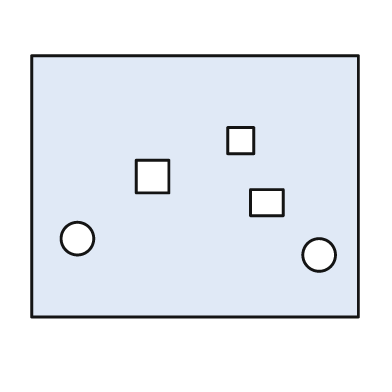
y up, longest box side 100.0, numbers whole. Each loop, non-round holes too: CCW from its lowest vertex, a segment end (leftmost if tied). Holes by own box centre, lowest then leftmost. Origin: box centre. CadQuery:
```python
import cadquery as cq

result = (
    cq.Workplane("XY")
    .moveTo(-50.0, -40.0)
    .lineTo(50.0, -40.0)
    .lineTo(50.0, 40.0)
    .lineTo(-50.0, 40.0)
    .close()
    .moveTo(38.0, -21.0)
    .circle(5.0)
    .moveTo(-36.0, -16.0)
    .circle(5.0)
    .moveTo(17.0, -9.0)
    .lineTo(27.0, -9.0)
    .lineTo(27.0, -1.0)
    .lineTo(17.0, -1.0)
    .close()
    .moveTo(-18.0, -2.0)
    .lineTo(-8.0, -2.0)
    .lineTo(-8.0, 8.0)
    .lineTo(-18.0, 8.0)
    .close()
    .moveTo(10.0, 10.0)
    .lineTo(18.0, 10.0)
    .lineTo(18.0, 18.0)
    .lineTo(10.0, 18.0)
    .close()
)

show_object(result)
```